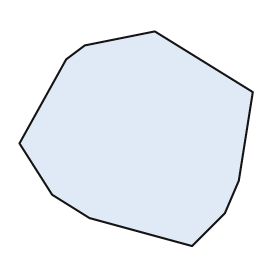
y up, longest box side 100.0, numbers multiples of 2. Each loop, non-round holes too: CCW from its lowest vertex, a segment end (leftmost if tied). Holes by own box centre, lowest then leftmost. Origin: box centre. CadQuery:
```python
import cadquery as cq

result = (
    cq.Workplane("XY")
    .moveTo(24.0, -46.0)
    .lineTo(38.0, -32.0)
    .lineTo(44.0, -18.0)
    .lineTo(50.0, 20.0)
    .lineTo(8.0, 46.0)
    .lineTo(-22.0, 40.0)
    .lineTo(-30.0, 34.0)
    .lineTo(-50.0, -2.0)
    .lineTo(-36.0, -24.0)
    .lineTo(-20.0, -34.0)
    .close()
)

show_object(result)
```